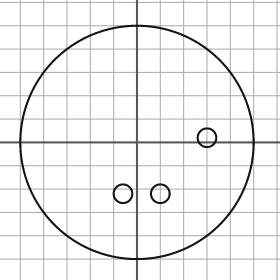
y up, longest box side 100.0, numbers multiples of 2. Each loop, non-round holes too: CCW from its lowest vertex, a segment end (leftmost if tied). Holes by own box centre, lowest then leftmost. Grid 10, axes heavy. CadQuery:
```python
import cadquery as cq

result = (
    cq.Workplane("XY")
    .moveTo(0.0, 0.0)
    .circle(50.0)
    .moveTo(-6.0, -22.0)
    .circle(4.0)
    .moveTo(10.0, -22.0)
    .circle(4.0)
    .moveTo(30.0, 2.0)
    .circle(4.0)
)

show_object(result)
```